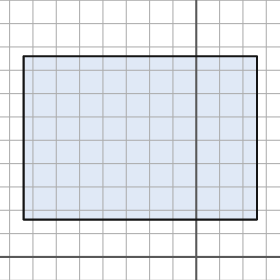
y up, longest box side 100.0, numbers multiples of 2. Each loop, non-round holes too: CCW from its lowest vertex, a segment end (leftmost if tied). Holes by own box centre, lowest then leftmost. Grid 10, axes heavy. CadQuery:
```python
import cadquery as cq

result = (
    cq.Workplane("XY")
    .moveTo(-74.0, 16.0)
    .lineTo(26.0, 16.0)
    .lineTo(26.0, 86.0)
    .lineTo(-74.0, 86.0)
    .close()
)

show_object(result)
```